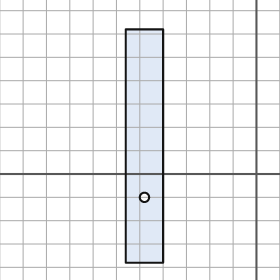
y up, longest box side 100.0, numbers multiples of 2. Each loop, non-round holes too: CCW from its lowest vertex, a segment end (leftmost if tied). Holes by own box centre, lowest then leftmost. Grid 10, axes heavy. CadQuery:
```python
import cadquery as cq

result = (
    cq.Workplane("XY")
    .moveTo(-56.0, -38.0)
    .lineTo(-40.0, -38.0)
    .lineTo(-40.0, 62.0)
    .lineTo(-56.0, 62.0)
    .close()
    .moveTo(-48.0, -10.0)
    .circle(2.0)
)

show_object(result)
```